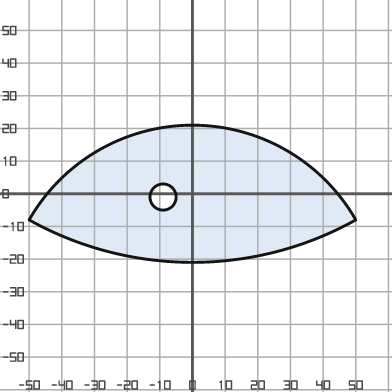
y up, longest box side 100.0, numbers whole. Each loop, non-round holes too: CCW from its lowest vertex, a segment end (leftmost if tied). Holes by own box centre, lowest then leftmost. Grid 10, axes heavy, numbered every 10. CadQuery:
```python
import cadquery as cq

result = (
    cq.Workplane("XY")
    .moveTo(-50.0, -8.0)
    .threePointArc((0.0, -21.0), (50.0, -8.0))
    .threePointArc((0.0, 21.0), (-50.0, -8.0))
    .close()
    .moveTo(-9.0, -1.0)
    .circle(4.0)
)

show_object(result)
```